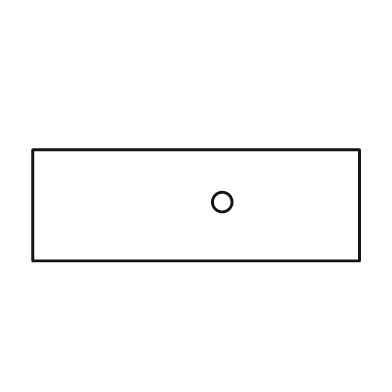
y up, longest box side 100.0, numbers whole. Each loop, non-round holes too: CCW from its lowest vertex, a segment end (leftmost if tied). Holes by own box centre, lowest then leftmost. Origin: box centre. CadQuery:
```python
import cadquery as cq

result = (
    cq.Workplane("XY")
    .moveTo(-50.0, -17.0)
    .lineTo(50.0, -17.0)
    .lineTo(50.0, 17.0)
    .lineTo(-50.0, 17.0)
    .close()
    .moveTo(8.0, 1.0)
    .circle(3.0)
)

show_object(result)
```